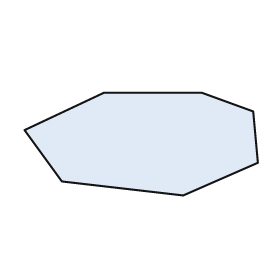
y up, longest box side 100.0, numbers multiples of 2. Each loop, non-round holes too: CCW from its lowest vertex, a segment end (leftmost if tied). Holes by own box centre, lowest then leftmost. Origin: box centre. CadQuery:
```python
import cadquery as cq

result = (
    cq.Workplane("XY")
    .moveTo(18.0, -22.0)
    .lineTo(50.0, -8.0)
    .lineTo(48.0, 14.0)
    .lineTo(26.0, 22.0)
    .lineTo(-16.0, 22.0)
    .lineTo(-50.0, 6.0)
    .lineTo(-34.0, -16.0)
    .close()
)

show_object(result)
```